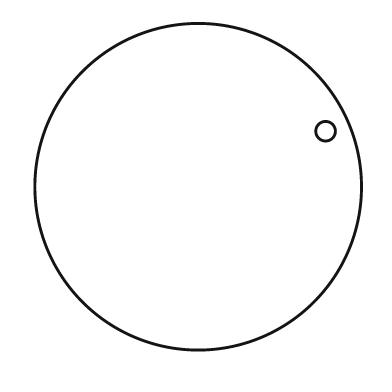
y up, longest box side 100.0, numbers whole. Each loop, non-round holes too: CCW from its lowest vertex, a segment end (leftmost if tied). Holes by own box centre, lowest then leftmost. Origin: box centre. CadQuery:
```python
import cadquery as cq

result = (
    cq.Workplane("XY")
    .moveTo(0.0, 0.0)
    .circle(50.0)
    .moveTo(39.0, 17.0)
    .circle(3.0)
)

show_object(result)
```